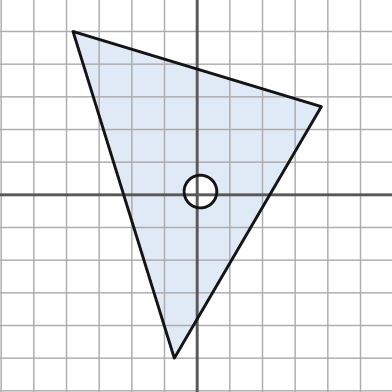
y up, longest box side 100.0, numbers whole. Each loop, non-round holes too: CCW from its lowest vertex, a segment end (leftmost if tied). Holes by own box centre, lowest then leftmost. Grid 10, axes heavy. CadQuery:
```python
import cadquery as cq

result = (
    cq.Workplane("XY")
    .moveTo(-7.0, -50.0)
    .lineTo(38.0, 27.0)
    .lineTo(-38.0, 50.0)
    .close()
    .moveTo(1.0, 1.0)
    .circle(5.0)
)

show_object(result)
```